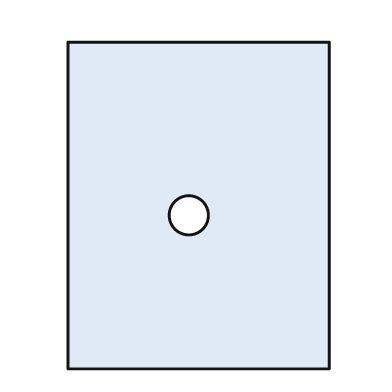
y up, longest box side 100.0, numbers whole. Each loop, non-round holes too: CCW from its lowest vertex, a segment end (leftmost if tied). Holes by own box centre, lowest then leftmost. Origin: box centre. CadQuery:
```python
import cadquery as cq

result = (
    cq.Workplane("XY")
    .moveTo(-40.0, -50.0)
    .lineTo(40.0, -50.0)
    .lineTo(40.0, 50.0)
    .lineTo(-40.0, 50.0)
    .close()
    .moveTo(-3.0, -3.0)
    .circle(6.0)
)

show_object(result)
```